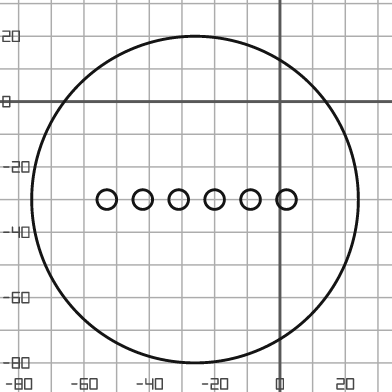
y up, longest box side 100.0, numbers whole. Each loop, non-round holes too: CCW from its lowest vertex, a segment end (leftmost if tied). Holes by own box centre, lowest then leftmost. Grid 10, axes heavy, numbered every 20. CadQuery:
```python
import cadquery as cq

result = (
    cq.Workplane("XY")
    .moveTo(-26.0, -30.0)
    .circle(50.0)
    .moveTo(-53.0, -30.0)
    .circle(3.0)
    .moveTo(-42.0, -30.0)
    .circle(3.0)
    .moveTo(-31.0, -30.0)
    .circle(3.0)
    .moveTo(-20.0, -30.0)
    .circle(3.0)
    .moveTo(-9.0, -30.0)
    .circle(3.0)
    .moveTo(2.0, -30.0)
    .circle(3.0)
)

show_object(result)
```